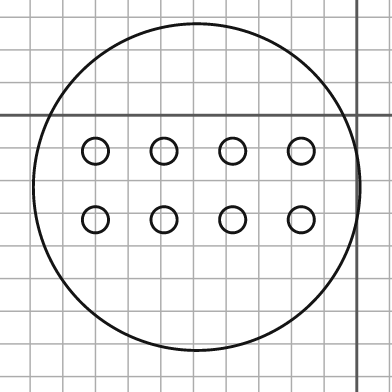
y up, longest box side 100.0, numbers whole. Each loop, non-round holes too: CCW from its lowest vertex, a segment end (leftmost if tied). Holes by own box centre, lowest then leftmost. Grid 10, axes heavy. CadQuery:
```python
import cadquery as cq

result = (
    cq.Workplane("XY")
    .moveTo(-49.0, -22.0)
    .circle(50.0)
    .moveTo(-80.0, -32.0)
    .circle(4.0)
    .moveTo(-59.0, -32.0)
    .circle(4.0)
    .moveTo(-38.0, -32.0)
    .circle(4.0)
    .moveTo(-17.0, -32.0)
    .circle(4.0)
    .moveTo(-80.0, -11.0)
    .circle(4.0)
    .moveTo(-59.0, -11.0)
    .circle(4.0)
    .moveTo(-38.0, -11.0)
    .circle(4.0)
    .moveTo(-17.0, -11.0)
    .circle(4.0)
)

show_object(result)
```